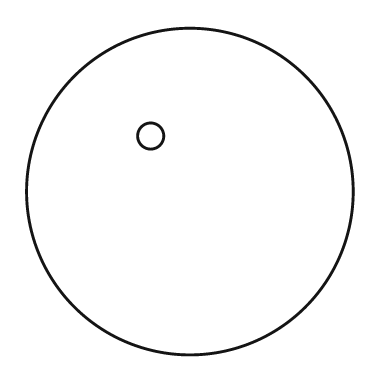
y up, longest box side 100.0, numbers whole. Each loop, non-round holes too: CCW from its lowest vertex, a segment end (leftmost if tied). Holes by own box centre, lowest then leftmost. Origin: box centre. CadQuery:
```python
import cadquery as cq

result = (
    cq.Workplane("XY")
    .moveTo(0.0, 0.0)
    .circle(50.0)
    .moveTo(-12.0, 17.0)
    .circle(4.0)
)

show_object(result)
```